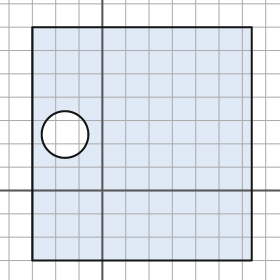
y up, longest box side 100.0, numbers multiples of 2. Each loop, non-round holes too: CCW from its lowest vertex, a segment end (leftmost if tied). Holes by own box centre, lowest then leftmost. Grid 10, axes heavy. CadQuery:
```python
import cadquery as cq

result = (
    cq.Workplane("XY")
    .moveTo(-30.0, -30.0)
    .lineTo(64.0, -30.0)
    .lineTo(64.0, 70.0)
    .lineTo(-30.0, 70.0)
    .close()
    .moveTo(-16.0, 24.0)
    .circle(10.0)
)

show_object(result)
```